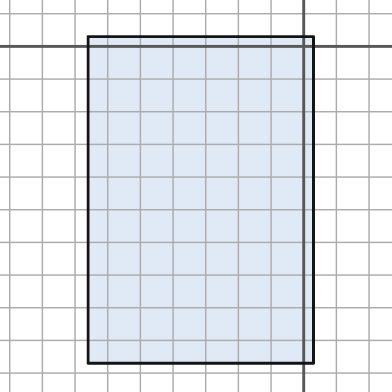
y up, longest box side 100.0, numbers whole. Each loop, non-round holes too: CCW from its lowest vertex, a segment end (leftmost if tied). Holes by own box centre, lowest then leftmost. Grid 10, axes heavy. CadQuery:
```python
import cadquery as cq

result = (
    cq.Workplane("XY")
    .moveTo(-66.0, -97.0)
    .lineTo(3.0, -97.0)
    .lineTo(3.0, 3.0)
    .lineTo(-66.0, 3.0)
    .close()
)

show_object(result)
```